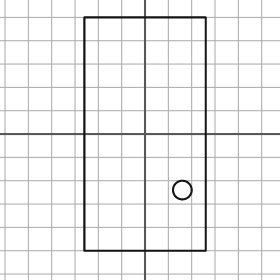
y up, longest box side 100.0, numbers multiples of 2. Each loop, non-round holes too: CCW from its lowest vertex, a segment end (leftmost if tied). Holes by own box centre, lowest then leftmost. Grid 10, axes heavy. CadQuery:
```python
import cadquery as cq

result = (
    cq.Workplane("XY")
    .moveTo(-26.0, -50.0)
    .lineTo(26.0, -50.0)
    .lineTo(26.0, 50.0)
    .lineTo(-26.0, 50.0)
    .close()
    .moveTo(16.0, -24.0)
    .circle(4.0)
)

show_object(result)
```